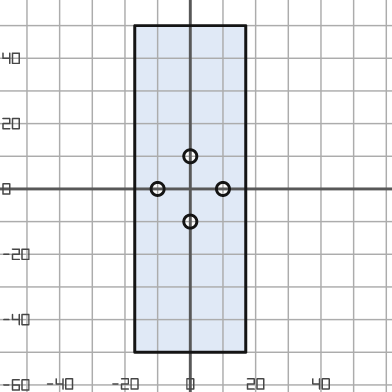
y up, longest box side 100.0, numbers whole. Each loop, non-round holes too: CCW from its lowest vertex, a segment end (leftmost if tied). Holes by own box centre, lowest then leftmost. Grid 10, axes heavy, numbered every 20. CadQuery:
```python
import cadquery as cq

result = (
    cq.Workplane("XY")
    .moveTo(-17.0, -50.0)
    .lineTo(17.0, -50.0)
    .lineTo(17.0, 50.0)
    .lineTo(-17.0, 50.0)
    .close()
    .moveTo(0.0, -10.0)
    .circle(2.0)
    .moveTo(-10.0, 0.0)
    .circle(2.0)
    .moveTo(10.0, 0.0)
    .circle(2.0)
    .moveTo(0.0, 10.0)
    .circle(2.0)
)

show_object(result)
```